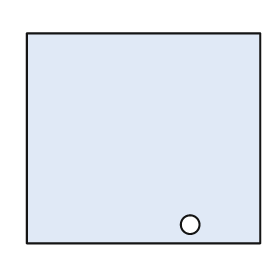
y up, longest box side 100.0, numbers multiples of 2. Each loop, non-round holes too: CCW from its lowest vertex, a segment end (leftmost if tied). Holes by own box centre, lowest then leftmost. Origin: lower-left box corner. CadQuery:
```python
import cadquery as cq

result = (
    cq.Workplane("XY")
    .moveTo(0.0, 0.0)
    .lineTo(100.0, 0.0)
    .lineTo(100.0, 90.0)
    .lineTo(0.0, 90.0)
    .close()
    .moveTo(70.0, 8.0)
    .circle(4.0)
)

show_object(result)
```